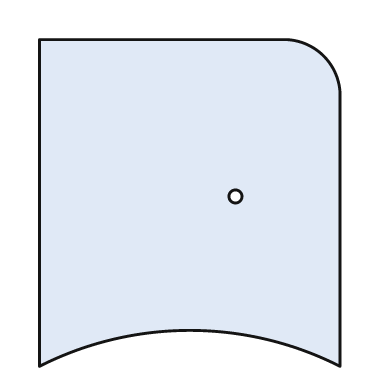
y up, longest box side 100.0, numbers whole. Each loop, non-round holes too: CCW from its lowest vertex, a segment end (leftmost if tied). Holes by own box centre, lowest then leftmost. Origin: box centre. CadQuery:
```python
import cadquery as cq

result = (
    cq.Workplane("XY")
    .moveTo(-46.0, -50.0)
    .threePointArc((0.0, -39.0), (46.0, -50.0))
    .lineTo(46.0, 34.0)
    .threePointArc((41.0, 45.0), (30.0, 50.0))
    .lineTo(-46.0, 50.0)
    .close()
    .moveTo(14.0, 2.0)
    .circle(2.0)
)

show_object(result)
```